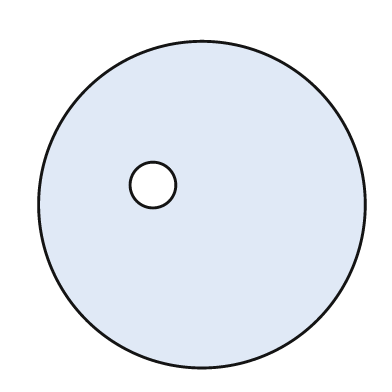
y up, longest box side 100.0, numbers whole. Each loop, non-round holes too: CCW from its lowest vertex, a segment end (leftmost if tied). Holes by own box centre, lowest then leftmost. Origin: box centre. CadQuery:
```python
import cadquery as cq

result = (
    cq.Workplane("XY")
    .moveTo(0.0, 0.0)
    .circle(50.0)
    .moveTo(-15.0, 6.0)
    .circle(7.0)
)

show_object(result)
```